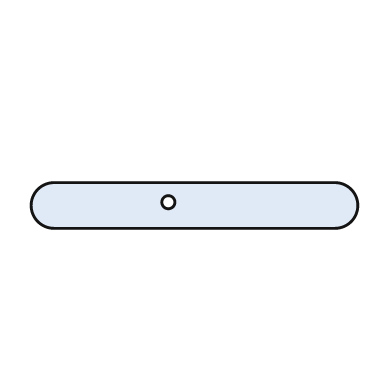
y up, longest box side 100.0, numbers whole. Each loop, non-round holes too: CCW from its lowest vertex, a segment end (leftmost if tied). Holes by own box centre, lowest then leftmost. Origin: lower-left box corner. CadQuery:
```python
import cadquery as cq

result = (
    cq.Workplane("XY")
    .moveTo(7.0, 0.0)
    .lineTo(93.0, 0.0)
    .threePointArc((100.0, 7.0), (93.0, 14.0))
    .lineTo(7.0, 14.0)
    .threePointArc((0.0, 7.0), (7.0, 0.0))
    .close()
    .moveTo(42.0, 8.0)
    .circle(2.0)
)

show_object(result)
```